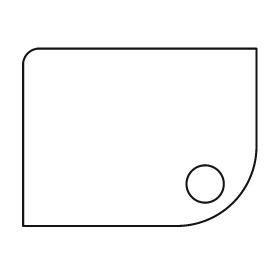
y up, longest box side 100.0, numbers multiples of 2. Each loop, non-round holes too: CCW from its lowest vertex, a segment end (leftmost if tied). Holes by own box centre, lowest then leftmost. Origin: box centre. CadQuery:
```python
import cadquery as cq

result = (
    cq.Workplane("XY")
    .moveTo(-50.0, -38.0)
    .lineTo(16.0, -38.0)
    .threePointArc((40.0, -28.0), (50.0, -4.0))
    .lineTo(50.0, 38.0)
    .lineTo(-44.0, 38.0)
    .threePointArc((-48.0, 36.0), (-50.0, 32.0))
    .close()
    .moveTo(28.0, -20.0)
    .circle(8.0)
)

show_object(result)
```